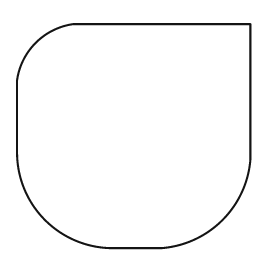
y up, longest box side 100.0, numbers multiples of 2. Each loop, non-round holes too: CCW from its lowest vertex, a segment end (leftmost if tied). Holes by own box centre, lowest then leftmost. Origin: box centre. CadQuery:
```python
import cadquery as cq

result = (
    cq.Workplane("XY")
    .moveTo(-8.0, -48.0)
    .lineTo(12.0, -48.0)
    .threePointArc((38.0, -36.0), (50.0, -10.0))
    .lineTo(50.0, 48.0)
    .lineTo(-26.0, 48.0)
    .threePointArc((-42.0, 40.0), (-50.0, 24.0))
    .lineTo(-50.0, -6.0)
    .threePointArc((-38.0, -36.0), (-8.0, -48.0))
    .close()
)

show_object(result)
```